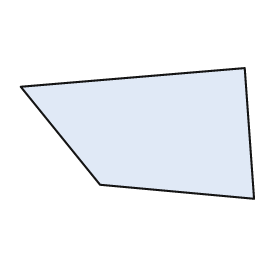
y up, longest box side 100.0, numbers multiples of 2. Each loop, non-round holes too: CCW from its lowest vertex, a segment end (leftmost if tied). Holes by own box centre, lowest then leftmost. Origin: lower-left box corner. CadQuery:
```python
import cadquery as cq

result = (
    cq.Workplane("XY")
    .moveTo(100.0, 0.0)
    .lineTo(96.0, 56.0)
    .lineTo(0.0, 48.0)
    .lineTo(34.0, 6.0)
    .close()
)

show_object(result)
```